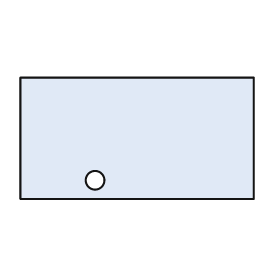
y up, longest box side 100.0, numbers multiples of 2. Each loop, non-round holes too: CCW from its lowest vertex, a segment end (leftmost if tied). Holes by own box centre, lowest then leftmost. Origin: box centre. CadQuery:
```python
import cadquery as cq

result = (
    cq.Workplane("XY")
    .moveTo(-50.0, -26.0)
    .lineTo(50.0, -26.0)
    .lineTo(50.0, 26.0)
    .lineTo(-50.0, 26.0)
    .close()
    .moveTo(-18.0, -18.0)
    .circle(4.0)
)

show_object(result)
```